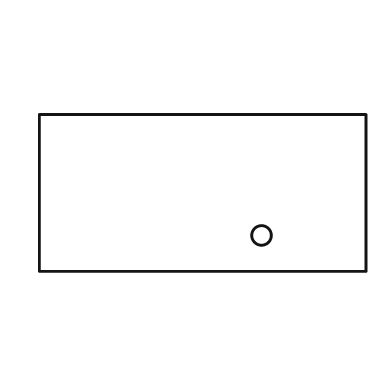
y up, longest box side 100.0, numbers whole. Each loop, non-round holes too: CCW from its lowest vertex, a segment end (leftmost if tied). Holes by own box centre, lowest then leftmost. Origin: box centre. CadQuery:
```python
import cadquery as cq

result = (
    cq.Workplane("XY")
    .moveTo(-50.0, -24.0)
    .lineTo(50.0, -24.0)
    .lineTo(50.0, 24.0)
    .lineTo(-50.0, 24.0)
    .close()
    .moveTo(18.0, -13.0)
    .circle(3.0)
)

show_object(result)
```